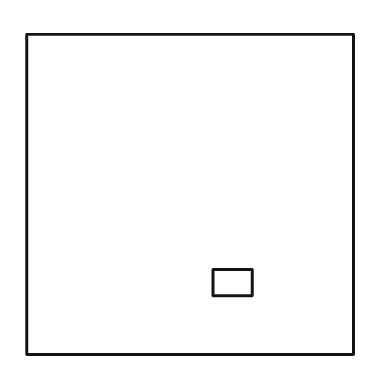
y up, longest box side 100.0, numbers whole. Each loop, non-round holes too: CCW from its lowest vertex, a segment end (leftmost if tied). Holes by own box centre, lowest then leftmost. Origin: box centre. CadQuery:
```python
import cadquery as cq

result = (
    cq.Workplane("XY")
    .moveTo(-50.0, -49.0)
    .lineTo(50.0, -49.0)
    .lineTo(50.0, 49.0)
    .lineTo(-50.0, 49.0)
    .close()
    .moveTo(7.0, -31.0)
    .lineTo(19.0, -31.0)
    .lineTo(19.0, -23.0)
    .lineTo(7.0, -23.0)
    .close()
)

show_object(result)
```